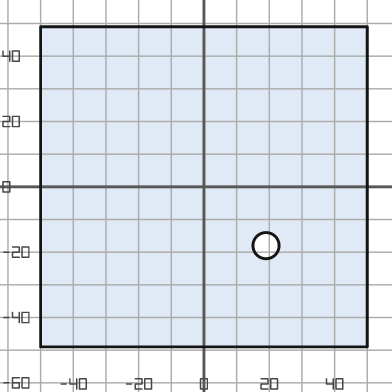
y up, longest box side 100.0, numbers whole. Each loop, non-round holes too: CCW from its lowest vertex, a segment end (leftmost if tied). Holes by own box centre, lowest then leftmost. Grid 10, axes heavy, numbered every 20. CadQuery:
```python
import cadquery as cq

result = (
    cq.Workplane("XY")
    .moveTo(-50.0, -49.0)
    .lineTo(50.0, -49.0)
    .lineTo(50.0, 49.0)
    .lineTo(-50.0, 49.0)
    .close()
    .moveTo(19.0, -18.0)
    .circle(4.0)
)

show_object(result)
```